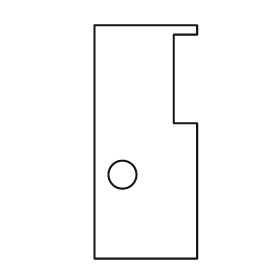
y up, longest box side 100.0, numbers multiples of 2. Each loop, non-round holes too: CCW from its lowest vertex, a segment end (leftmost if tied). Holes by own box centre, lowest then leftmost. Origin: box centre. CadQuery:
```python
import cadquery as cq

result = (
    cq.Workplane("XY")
    .moveTo(-22.0, -50.0)
    .lineTo(22.0, -50.0)
    .lineTo(22.0, 8.0)
    .lineTo(12.0, 8.0)
    .lineTo(12.0, 46.0)
    .lineTo(22.0, 46.0)
    .lineTo(22.0, 50.0)
    .lineTo(-22.0, 50.0)
    .close()
    .moveTo(-10.0, -14.0)
    .circle(6.0)
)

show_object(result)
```